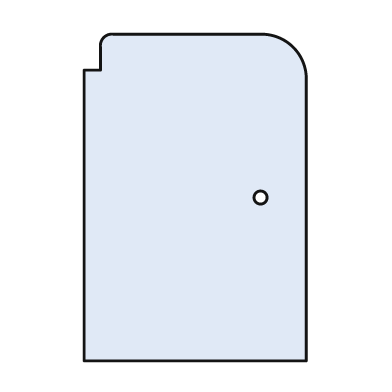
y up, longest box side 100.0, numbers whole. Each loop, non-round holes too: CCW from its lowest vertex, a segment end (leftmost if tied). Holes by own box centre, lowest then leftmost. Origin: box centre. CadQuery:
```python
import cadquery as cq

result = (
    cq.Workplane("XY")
    .moveTo(-34.0, -50.0)
    .lineTo(34.0, -50.0)
    .lineTo(34.0, 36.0)
    .threePointArc((30.0, 46.0), (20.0, 50.0))
    .lineTo(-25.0, 50.0)
    .threePointArc((-28.0, 49.0), (-29.0, 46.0))
    .lineTo(-29.0, 39.0)
    .lineTo(-34.0, 39.0)
    .close()
    .moveTo(20.0, 0.0)
    .circle(2.0)
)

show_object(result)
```